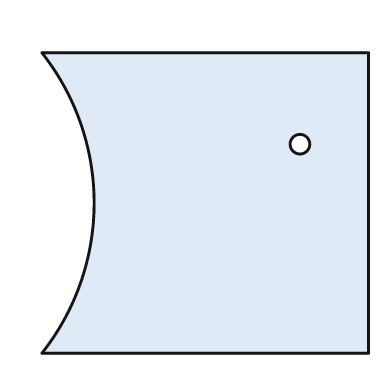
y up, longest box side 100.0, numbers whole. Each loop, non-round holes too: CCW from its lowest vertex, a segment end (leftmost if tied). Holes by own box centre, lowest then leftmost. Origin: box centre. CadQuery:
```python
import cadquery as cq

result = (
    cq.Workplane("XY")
    .moveTo(-50.0, -46.0)
    .lineTo(50.0, -46.0)
    .lineTo(50.0, 46.0)
    .lineTo(-50.0, 46.0)
    .threePointArc((-34.0, 0.0), (-50.0, -46.0))
    .close()
    .moveTo(29.0, 18.0)
    .circle(3.0)
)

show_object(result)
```